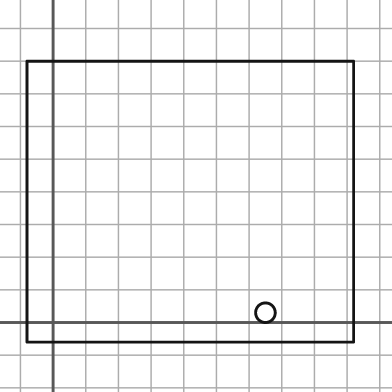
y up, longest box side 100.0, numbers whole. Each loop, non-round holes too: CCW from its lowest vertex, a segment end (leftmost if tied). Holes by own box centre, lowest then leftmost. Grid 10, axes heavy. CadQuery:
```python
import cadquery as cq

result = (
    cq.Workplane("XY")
    .moveTo(-8.0, -6.0)
    .lineTo(92.0, -6.0)
    .lineTo(92.0, 80.0)
    .lineTo(-8.0, 80.0)
    .close()
    .moveTo(65.0, 3.0)
    .circle(3.0)
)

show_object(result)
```